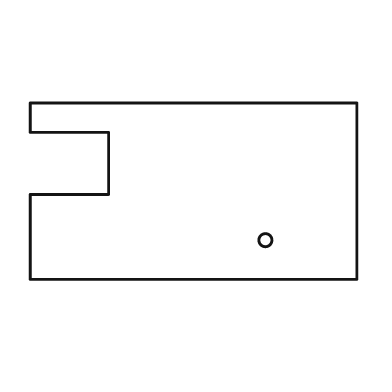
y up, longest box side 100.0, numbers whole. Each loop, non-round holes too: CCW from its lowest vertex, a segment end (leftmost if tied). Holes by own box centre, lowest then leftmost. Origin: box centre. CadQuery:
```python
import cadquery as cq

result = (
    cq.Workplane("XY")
    .moveTo(-50.0, -27.0)
    .lineTo(50.0, -27.0)
    .lineTo(50.0, 27.0)
    .lineTo(-50.0, 27.0)
    .lineTo(-50.0, 18.0)
    .lineTo(-26.0, 18.0)
    .lineTo(-26.0, -1.0)
    .lineTo(-50.0, -1.0)
    .close()
    .moveTo(22.0, -15.0)
    .circle(2.0)
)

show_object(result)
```